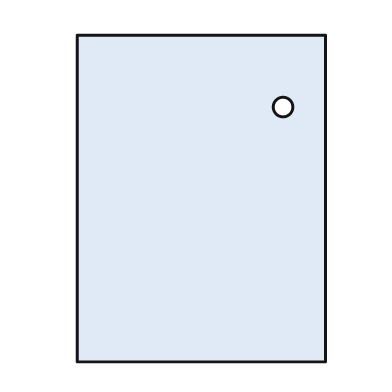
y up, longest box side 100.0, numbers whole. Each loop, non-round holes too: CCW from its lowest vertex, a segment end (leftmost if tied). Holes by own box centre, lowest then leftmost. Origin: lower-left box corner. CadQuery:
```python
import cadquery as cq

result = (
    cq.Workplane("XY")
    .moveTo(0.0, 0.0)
    .lineTo(76.0, 0.0)
    .lineTo(76.0, 100.0)
    .lineTo(0.0, 100.0)
    .close()
    .moveTo(63.0, 78.0)
    .circle(3.0)
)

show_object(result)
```